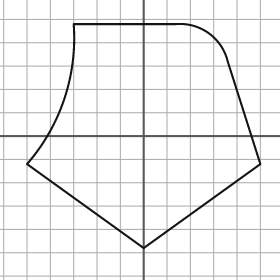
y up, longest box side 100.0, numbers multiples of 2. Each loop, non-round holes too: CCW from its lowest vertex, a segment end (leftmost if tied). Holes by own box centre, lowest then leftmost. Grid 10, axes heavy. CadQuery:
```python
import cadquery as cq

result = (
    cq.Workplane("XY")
    .moveTo(0.0, -48.0)
    .lineTo(50.0, -12.0)
    .lineTo(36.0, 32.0)
    .threePointArc((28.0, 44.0), (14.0, 48.0))
    .lineTo(-30.0, 48.0)
    .threePointArc((-34.0, 16.0), (-50.0, -12.0))
    .close()
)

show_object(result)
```